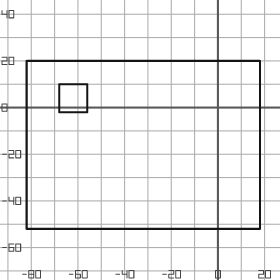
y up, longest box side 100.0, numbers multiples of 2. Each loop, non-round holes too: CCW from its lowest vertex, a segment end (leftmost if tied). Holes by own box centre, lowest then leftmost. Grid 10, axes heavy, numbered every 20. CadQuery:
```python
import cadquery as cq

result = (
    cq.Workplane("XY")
    .moveTo(-82.0, -52.0)
    .lineTo(18.0, -52.0)
    .lineTo(18.0, 20.0)
    .lineTo(-82.0, 20.0)
    .close()
    .moveTo(-68.0, -2.0)
    .lineTo(-56.0, -2.0)
    .lineTo(-56.0, 10.0)
    .lineTo(-68.0, 10.0)
    .close()
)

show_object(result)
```